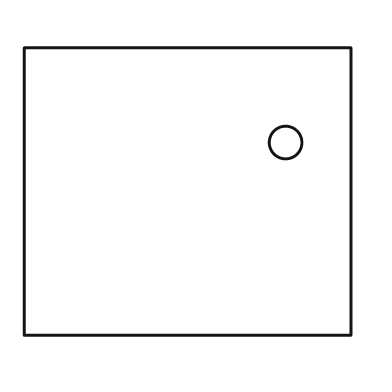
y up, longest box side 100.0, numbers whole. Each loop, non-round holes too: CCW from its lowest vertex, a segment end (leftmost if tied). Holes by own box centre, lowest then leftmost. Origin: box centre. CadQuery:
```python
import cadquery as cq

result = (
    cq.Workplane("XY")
    .moveTo(-50.0, -44.0)
    .lineTo(50.0, -44.0)
    .lineTo(50.0, 44.0)
    .lineTo(-50.0, 44.0)
    .close()
    .moveTo(30.0, 15.0)
    .circle(5.0)
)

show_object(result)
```